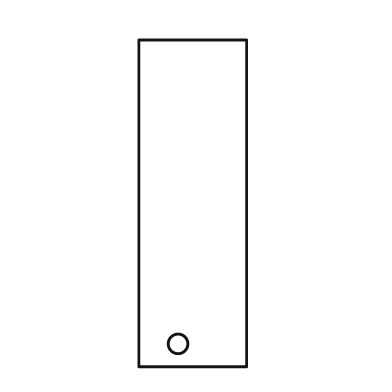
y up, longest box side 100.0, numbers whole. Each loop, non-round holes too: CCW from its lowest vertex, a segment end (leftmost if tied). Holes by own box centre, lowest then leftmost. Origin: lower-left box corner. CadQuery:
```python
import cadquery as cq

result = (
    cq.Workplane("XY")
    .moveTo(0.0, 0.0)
    .lineTo(33.0, 0.0)
    .lineTo(33.0, 100.0)
    .lineTo(0.0, 100.0)
    .close()
    .moveTo(12.0, 7.0)
    .circle(3.0)
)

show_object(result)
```